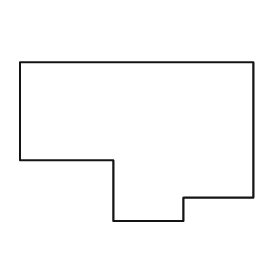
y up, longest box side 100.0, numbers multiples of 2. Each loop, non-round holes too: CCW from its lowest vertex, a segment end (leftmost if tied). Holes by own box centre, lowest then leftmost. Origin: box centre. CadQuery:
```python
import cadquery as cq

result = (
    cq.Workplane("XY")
    .moveTo(-10.0, -34.0)
    .lineTo(20.0, -34.0)
    .lineTo(20.0, -24.0)
    .lineTo(50.0, -24.0)
    .lineTo(50.0, 34.0)
    .lineTo(-50.0, 34.0)
    .lineTo(-50.0, -8.0)
    .lineTo(-10.0, -8.0)
    .close()
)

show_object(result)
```